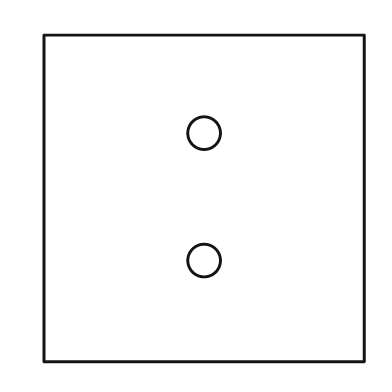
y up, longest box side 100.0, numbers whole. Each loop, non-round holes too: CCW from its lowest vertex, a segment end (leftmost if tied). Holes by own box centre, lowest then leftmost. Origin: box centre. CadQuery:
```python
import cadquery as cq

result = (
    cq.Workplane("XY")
    .moveTo(-49.0, -50.0)
    .lineTo(49.0, -50.0)
    .lineTo(49.0, 50.0)
    .lineTo(-49.0, 50.0)
    .close()
    .moveTo(0.0, -19.0)
    .circle(5.0)
    .moveTo(0.0, 20.0)
    .circle(5.0)
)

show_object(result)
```